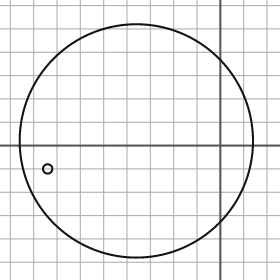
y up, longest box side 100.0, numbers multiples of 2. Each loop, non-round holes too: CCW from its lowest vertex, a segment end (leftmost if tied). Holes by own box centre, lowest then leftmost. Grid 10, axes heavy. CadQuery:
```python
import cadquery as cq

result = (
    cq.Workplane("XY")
    .moveTo(-36.0, 2.0)
    .circle(50.0)
    .moveTo(-74.0, -10.0)
    .circle(2.0)
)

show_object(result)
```